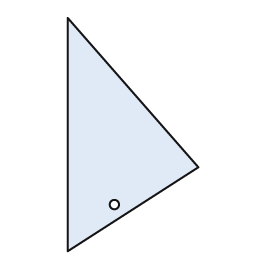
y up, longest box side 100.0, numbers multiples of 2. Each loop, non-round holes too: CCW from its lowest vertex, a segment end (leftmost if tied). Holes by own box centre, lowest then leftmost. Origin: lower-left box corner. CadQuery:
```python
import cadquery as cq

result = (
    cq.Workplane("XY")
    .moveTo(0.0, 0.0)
    .lineTo(56.0, 36.0)
    .lineTo(0.0, 100.0)
    .close()
    .moveTo(20.0, 20.0)
    .circle(2.0)
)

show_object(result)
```